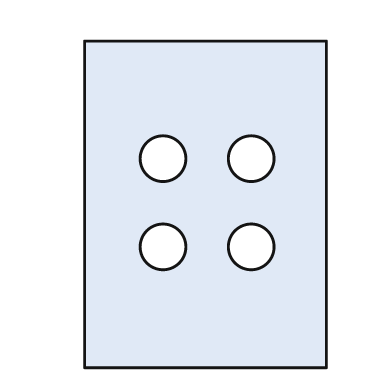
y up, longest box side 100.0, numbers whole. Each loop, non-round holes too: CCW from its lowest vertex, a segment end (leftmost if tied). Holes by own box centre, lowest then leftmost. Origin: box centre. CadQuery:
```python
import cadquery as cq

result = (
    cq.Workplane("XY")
    .moveTo(-37.0, -50.0)
    .lineTo(37.0, -50.0)
    .lineTo(37.0, 50.0)
    .lineTo(-37.0, 50.0)
    .close()
    .moveTo(-13.0, -13.0)
    .circle(7.0)
    .moveTo(14.0, -13.0)
    .circle(7.0)
    .moveTo(-13.0, 14.0)
    .circle(7.0)
    .moveTo(14.0, 14.0)
    .circle(7.0)
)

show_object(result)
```